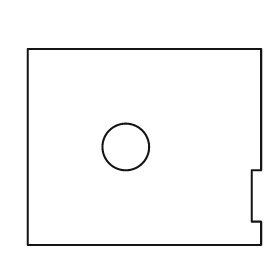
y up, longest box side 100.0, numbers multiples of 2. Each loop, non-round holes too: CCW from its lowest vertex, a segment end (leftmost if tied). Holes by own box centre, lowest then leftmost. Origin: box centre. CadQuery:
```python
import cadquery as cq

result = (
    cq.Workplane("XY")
    .moveTo(-50.0, -42.0)
    .lineTo(50.0, -42.0)
    .lineTo(50.0, -32.0)
    .lineTo(46.0, -32.0)
    .lineTo(46.0, -10.0)
    .lineTo(50.0, -10.0)
    .lineTo(50.0, 42.0)
    .lineTo(-50.0, 42.0)
    .close()
    .moveTo(-8.0, 0.0)
    .circle(10.0)
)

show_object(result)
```